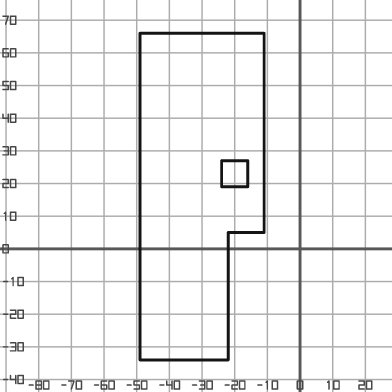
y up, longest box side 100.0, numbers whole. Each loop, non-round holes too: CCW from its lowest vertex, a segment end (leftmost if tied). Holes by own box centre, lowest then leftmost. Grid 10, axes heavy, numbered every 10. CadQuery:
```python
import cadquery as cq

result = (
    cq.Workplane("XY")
    .moveTo(-49.0, -34.0)
    .lineTo(-22.0, -34.0)
    .lineTo(-22.0, 5.0)
    .lineTo(-11.0, 5.0)
    .lineTo(-11.0, 66.0)
    .lineTo(-49.0, 66.0)
    .close()
    .moveTo(-24.0, 19.0)
    .lineTo(-16.0, 19.0)
    .lineTo(-16.0, 27.0)
    .lineTo(-24.0, 27.0)
    .close()
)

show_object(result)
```